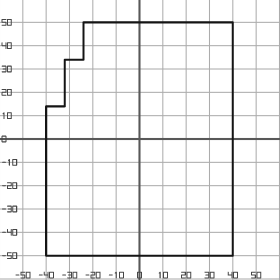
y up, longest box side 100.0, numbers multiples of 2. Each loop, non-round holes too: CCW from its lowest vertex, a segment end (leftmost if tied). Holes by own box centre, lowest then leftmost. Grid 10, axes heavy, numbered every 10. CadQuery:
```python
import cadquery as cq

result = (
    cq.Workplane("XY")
    .moveTo(-40.0, -50.0)
    .lineTo(40.0, -50.0)
    .lineTo(40.0, 50.0)
    .lineTo(-24.0, 50.0)
    .lineTo(-24.0, 34.0)
    .lineTo(-32.0, 34.0)
    .lineTo(-32.0, 14.0)
    .lineTo(-40.0, 14.0)
    .close()
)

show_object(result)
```